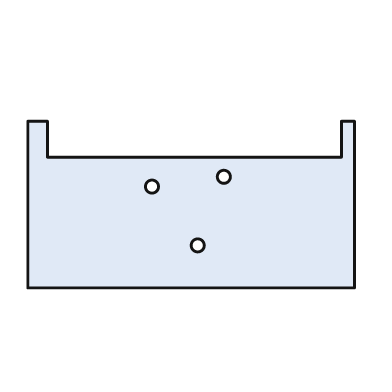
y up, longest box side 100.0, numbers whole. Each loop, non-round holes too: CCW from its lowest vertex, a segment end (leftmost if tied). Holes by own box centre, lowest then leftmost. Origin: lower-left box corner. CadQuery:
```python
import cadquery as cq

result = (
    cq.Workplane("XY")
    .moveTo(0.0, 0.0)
    .lineTo(100.0, 0.0)
    .lineTo(100.0, 51.0)
    .lineTo(96.0, 51.0)
    .lineTo(96.0, 40.0)
    .lineTo(6.0, 40.0)
    .lineTo(6.0, 51.0)
    .lineTo(0.0, 51.0)
    .close()
    .moveTo(52.0, 13.0)
    .circle(2.0)
    .moveTo(38.0, 31.0)
    .circle(2.0)
    .moveTo(60.0, 34.0)
    .circle(2.0)
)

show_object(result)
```